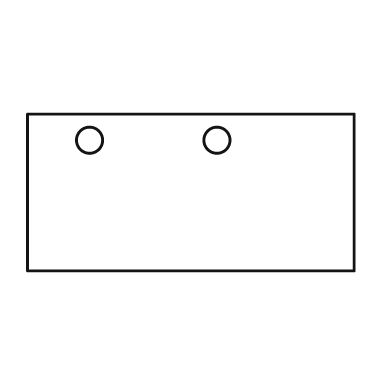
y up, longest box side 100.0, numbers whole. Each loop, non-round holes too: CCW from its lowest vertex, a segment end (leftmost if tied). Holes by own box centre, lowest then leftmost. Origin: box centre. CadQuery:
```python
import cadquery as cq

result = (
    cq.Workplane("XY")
    .moveTo(-50.0, -24.0)
    .lineTo(50.0, -24.0)
    .lineTo(50.0, 24.0)
    .lineTo(-50.0, 24.0)
    .close()
    .moveTo(-31.0, 16.0)
    .circle(4.0)
    .moveTo(8.0, 16.0)
    .circle(4.0)
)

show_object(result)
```